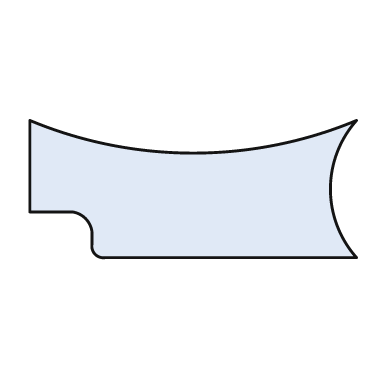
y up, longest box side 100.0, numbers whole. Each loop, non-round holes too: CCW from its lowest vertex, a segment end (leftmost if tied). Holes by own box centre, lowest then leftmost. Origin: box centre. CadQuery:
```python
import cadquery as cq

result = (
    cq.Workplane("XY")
    .moveTo(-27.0, -21.0)
    .lineTo(50.0, -21.0)
    .threePointArc((42.0, 0.0), (50.0, 21.0))
    .threePointArc((0.0, 11.0), (-50.0, 21.0))
    .lineTo(-50.0, -7.0)
    .lineTo(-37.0, -7.0)
    .threePointArc((-33.0, -9.0), (-31.0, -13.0))
    .lineTo(-31.0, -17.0)
    .threePointArc((-30.0, -20.0), (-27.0, -21.0))
    .close()
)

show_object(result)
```